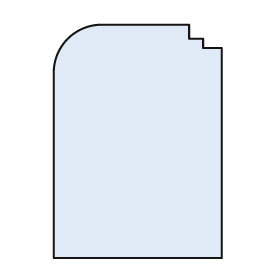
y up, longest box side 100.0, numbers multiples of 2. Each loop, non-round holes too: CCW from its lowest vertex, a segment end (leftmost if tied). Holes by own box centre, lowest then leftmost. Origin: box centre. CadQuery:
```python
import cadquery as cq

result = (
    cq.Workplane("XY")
    .moveTo(-36.0, -50.0)
    .lineTo(36.0, -50.0)
    .lineTo(36.0, 40.0)
    .lineTo(28.0, 40.0)
    .lineTo(28.0, 44.0)
    .lineTo(22.0, 44.0)
    .lineTo(22.0, 50.0)
    .lineTo(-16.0, 50.0)
    .threePointArc((-30.0, 44.0), (-36.0, 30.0))
    .close()
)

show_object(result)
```